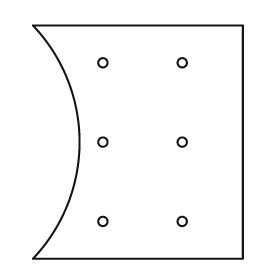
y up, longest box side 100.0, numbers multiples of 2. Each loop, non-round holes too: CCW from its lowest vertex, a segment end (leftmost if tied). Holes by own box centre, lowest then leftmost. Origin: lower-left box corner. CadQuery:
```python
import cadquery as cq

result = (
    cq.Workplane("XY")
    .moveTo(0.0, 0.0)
    .lineTo(90.0, 0.0)
    .lineTo(90.0, 100.0)
    .lineTo(0.0, 100.0)
    .threePointArc((20.0, 50.0), (0.0, 0.0))
    .close()
    .moveTo(30.0, 16.0)
    .circle(2.0)
    .moveTo(64.0, 16.0)
    .circle(2.0)
    .moveTo(30.0, 50.0)
    .circle(2.0)
    .moveTo(64.0, 50.0)
    .circle(2.0)
    .moveTo(30.0, 84.0)
    .circle(2.0)
    .moveTo(64.0, 84.0)
    .circle(2.0)
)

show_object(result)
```